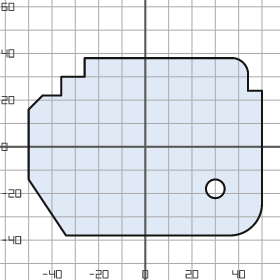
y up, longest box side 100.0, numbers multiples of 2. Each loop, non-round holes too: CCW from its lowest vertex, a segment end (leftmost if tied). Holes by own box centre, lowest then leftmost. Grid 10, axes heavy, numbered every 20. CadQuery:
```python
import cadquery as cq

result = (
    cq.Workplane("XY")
    .moveTo(-34.0, -38.0)
    .lineTo(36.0, -38.0)
    .threePointArc((46.0, -34.0), (50.0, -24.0))
    .lineTo(50.0, 24.0)
    .lineTo(44.0, 24.0)
    .lineTo(44.0, 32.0)
    .threePointArc((42.0, 36.0), (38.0, 38.0))
    .lineTo(-26.0, 38.0)
    .lineTo(-26.0, 30.0)
    .lineTo(-36.0, 30.0)
    .lineTo(-36.0, 22.0)
    .lineTo(-44.0, 22.0)
    .lineTo(-50.0, 16.0)
    .lineTo(-50.0, -14.0)
    .close()
    .moveTo(30.0, -18.0)
    .circle(4.0)
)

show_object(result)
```